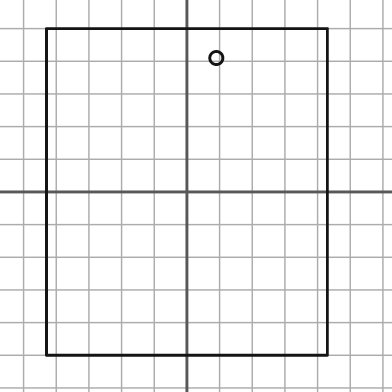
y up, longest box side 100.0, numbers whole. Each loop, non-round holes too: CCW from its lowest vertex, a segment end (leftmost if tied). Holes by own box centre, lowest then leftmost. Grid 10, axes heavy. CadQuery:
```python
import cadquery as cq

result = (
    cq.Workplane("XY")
    .moveTo(-43.0, -50.0)
    .lineTo(43.0, -50.0)
    .lineTo(43.0, 50.0)
    .lineTo(-43.0, 50.0)
    .close()
    .moveTo(9.0, 41.0)
    .circle(2.0)
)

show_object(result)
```